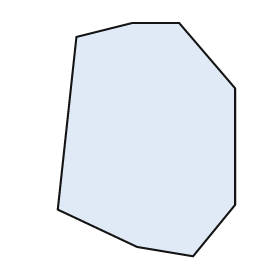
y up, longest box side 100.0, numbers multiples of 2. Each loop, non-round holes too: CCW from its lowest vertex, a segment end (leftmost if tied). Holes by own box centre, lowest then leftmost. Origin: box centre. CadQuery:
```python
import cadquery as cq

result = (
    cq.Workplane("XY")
    .moveTo(20.0, -50.0)
    .lineTo(38.0, -28.0)
    .lineTo(38.0, 22.0)
    .lineTo(14.0, 50.0)
    .lineTo(-6.0, 50.0)
    .lineTo(-30.0, 44.0)
    .lineTo(-38.0, -30.0)
    .lineTo(-4.0, -46.0)
    .close()
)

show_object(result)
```